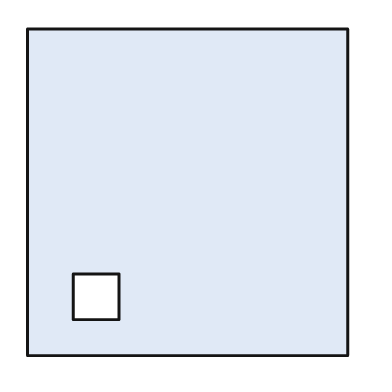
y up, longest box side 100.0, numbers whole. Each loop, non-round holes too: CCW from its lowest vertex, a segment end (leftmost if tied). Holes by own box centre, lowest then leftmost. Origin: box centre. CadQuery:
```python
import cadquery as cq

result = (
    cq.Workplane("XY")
    .moveTo(-49.0, -50.0)
    .lineTo(49.0, -50.0)
    .lineTo(49.0, 50.0)
    .lineTo(-49.0, 50.0)
    .close()
    .moveTo(-35.0, -39.0)
    .lineTo(-21.0, -39.0)
    .lineTo(-21.0, -25.0)
    .lineTo(-35.0, -25.0)
    .close()
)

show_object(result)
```